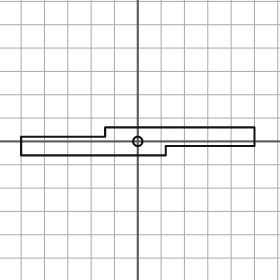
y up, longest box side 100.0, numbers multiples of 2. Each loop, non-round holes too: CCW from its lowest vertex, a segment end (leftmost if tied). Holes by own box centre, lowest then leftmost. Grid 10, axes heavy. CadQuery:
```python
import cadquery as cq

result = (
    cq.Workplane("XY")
    .moveTo(-50.0, -6.0)
    .lineTo(12.0, -6.0)
    .lineTo(12.0, -2.0)
    .lineTo(50.0, -2.0)
    .lineTo(50.0, 6.0)
    .lineTo(-14.0, 6.0)
    .lineTo(-14.0, 2.0)
    .lineTo(-50.0, 2.0)
    .close()
    .moveTo(0.0, 0.0)
    .circle(2.0)
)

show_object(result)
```